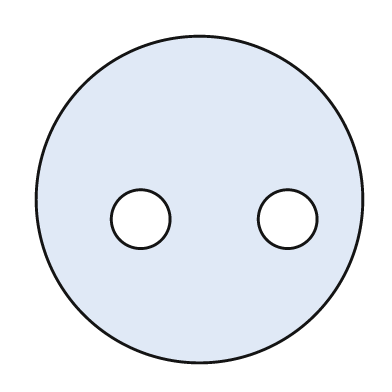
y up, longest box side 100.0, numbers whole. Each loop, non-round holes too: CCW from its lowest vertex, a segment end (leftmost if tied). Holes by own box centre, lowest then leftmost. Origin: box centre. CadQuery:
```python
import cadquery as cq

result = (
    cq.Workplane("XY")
    .moveTo(0.0, 0.0)
    .circle(50.0)
    .moveTo(-18.0, -6.0)
    .circle(9.0)
    .moveTo(27.0, -6.0)
    .circle(9.0)
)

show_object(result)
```